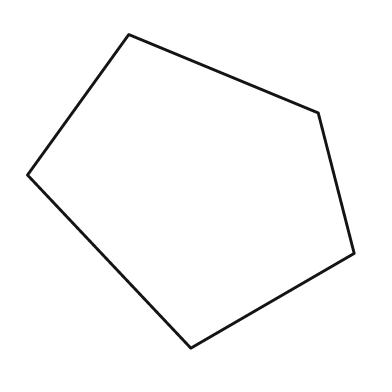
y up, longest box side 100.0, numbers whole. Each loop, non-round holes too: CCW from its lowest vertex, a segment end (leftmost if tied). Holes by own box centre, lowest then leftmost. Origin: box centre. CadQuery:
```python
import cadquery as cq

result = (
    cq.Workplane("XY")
    .moveTo(0.0, -48.0)
    .lineTo(50.0, -19.0)
    .lineTo(39.0, 24.0)
    .lineTo(-19.0, 48.0)
    .lineTo(-50.0, 5.0)
    .close()
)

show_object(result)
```